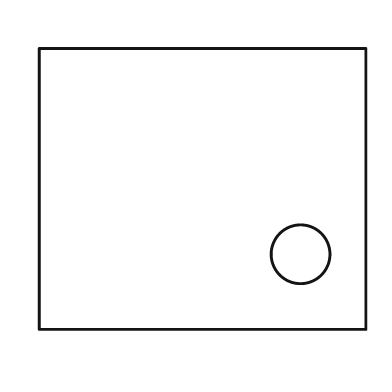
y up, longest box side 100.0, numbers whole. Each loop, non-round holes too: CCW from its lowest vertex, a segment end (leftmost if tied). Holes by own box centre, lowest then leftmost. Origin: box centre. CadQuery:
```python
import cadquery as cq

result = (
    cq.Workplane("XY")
    .moveTo(-50.0, -43.0)
    .lineTo(50.0, -43.0)
    .lineTo(50.0, 43.0)
    .lineTo(-50.0, 43.0)
    .close()
    .moveTo(30.0, -20.0)
    .circle(9.0)
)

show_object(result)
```